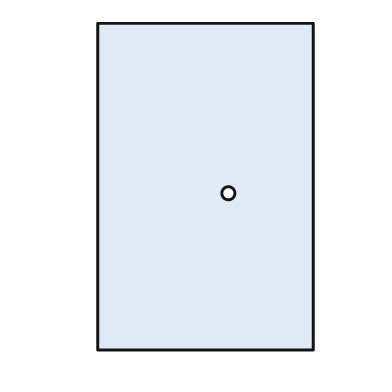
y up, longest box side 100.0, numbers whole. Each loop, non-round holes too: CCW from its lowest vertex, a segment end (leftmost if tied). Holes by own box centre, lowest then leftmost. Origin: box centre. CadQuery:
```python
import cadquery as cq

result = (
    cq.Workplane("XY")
    .moveTo(-33.0, -50.0)
    .lineTo(33.0, -50.0)
    .lineTo(33.0, 50.0)
    .lineTo(-33.0, 50.0)
    .close()
    .moveTo(7.0, -2.0)
    .circle(2.0)
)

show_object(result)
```